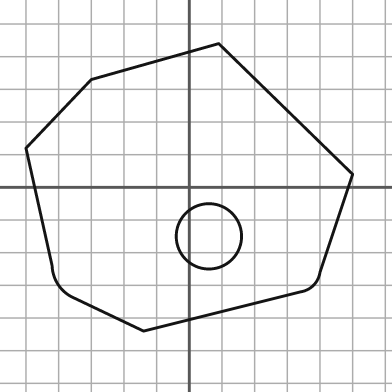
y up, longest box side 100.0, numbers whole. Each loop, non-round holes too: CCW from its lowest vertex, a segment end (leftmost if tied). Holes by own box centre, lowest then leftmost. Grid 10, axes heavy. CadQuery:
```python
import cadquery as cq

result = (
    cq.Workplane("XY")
    .moveTo(-14.0, -44.0)
    .lineTo(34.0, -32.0)
    .threePointArc((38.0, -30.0), (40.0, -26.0))
    .lineTo(50.0, 4.0)
    .lineTo(9.0, 44.0)
    .lineTo(-30.0, 33.0)
    .lineTo(-50.0, 12.0)
    .lineTo(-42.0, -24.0)
    .threePointArc((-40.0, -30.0), (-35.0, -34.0))
    .close()
    .moveTo(6.0, -15.0)
    .circle(10.0)
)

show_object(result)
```